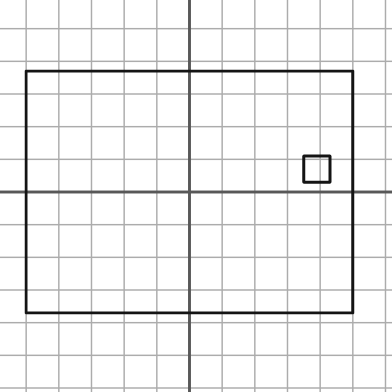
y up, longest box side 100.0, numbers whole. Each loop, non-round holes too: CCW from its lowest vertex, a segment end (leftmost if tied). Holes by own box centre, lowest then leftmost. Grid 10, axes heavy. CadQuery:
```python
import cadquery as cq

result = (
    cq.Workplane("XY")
    .moveTo(-50.0, -37.0)
    .lineTo(50.0, -37.0)
    .lineTo(50.0, 37.0)
    .lineTo(-50.0, 37.0)
    .close()
    .moveTo(35.0, 3.0)
    .lineTo(43.0, 3.0)
    .lineTo(43.0, 11.0)
    .lineTo(35.0, 11.0)
    .close()
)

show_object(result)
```